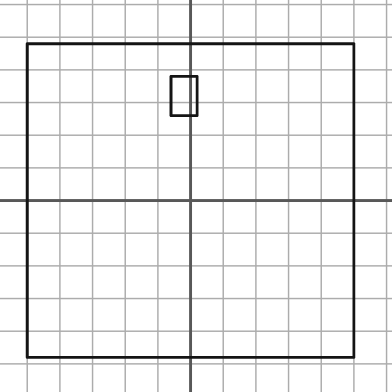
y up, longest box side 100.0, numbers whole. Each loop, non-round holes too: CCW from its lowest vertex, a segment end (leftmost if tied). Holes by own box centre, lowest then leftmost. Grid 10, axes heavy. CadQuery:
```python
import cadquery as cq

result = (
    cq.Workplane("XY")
    .moveTo(-50.0, -48.0)
    .lineTo(50.0, -48.0)
    .lineTo(50.0, 48.0)
    .lineTo(-50.0, 48.0)
    .close()
    .moveTo(-6.0, 26.0)
    .lineTo(2.0, 26.0)
    .lineTo(2.0, 38.0)
    .lineTo(-6.0, 38.0)
    .close()
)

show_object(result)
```